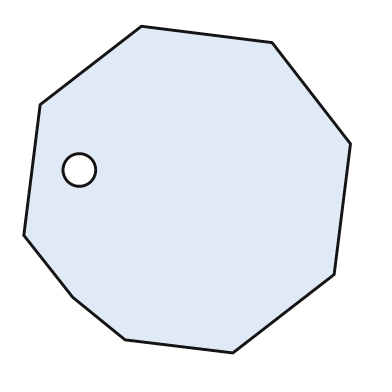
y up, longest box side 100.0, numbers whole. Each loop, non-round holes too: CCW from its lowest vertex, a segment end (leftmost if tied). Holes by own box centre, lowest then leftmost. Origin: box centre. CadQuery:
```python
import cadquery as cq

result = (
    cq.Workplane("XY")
    .moveTo(14.0, -50.0)
    .lineTo(45.0, -26.0)
    .lineTo(50.0, 14.0)
    .lineTo(26.0, 45.0)
    .lineTo(-14.0, 50.0)
    .lineTo(-45.0, 26.0)
    .lineTo(-50.0, -14.0)
    .lineTo(-35.0, -33.0)
    .lineTo(-19.0, -46.0)
    .close()
    .moveTo(-33.0, 6.0)
    .circle(5.0)
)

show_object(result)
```